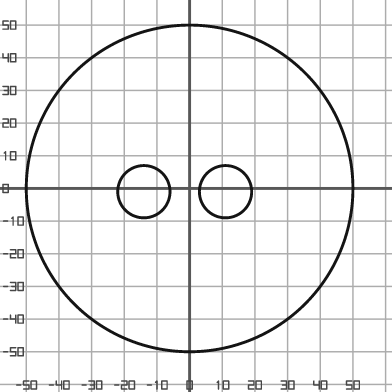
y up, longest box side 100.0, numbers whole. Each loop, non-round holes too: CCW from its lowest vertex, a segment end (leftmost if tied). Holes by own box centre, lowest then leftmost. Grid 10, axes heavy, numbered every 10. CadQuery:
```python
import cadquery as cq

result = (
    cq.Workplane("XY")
    .moveTo(0.0, 0.0)
    .circle(50.0)
    .moveTo(-14.0, -1.0)
    .circle(8.0)
    .moveTo(11.0, -1.0)
    .circle(8.0)
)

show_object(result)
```